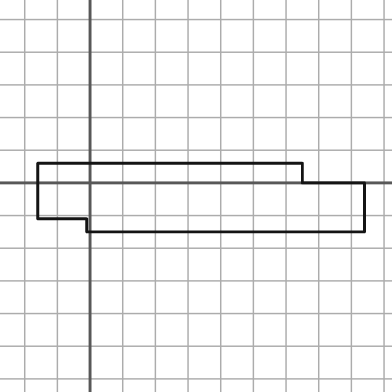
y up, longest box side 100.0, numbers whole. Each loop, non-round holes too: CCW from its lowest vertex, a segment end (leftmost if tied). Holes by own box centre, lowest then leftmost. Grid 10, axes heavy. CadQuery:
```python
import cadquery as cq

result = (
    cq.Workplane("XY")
    .moveTo(-1.0, -15.0)
    .lineTo(84.0, -15.0)
    .lineTo(84.0, 0.0)
    .lineTo(65.0, 0.0)
    .lineTo(65.0, 6.0)
    .lineTo(-16.0, 6.0)
    .lineTo(-16.0, -11.0)
    .lineTo(-1.0, -11.0)
    .close()
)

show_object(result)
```